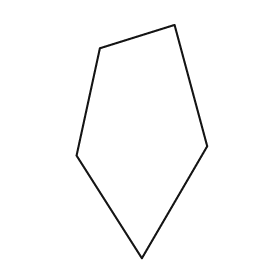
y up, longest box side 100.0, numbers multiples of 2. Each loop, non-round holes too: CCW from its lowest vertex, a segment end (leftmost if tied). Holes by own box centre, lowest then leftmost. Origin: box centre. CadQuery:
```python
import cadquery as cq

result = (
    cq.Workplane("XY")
    .moveTo(0.0, -50.0)
    .lineTo(28.0, -2.0)
    .lineTo(14.0, 50.0)
    .lineTo(-18.0, 40.0)
    .lineTo(-28.0, -6.0)
    .close()
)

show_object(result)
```